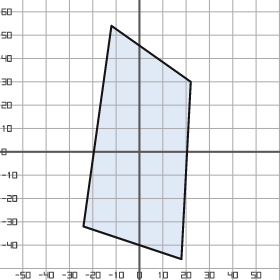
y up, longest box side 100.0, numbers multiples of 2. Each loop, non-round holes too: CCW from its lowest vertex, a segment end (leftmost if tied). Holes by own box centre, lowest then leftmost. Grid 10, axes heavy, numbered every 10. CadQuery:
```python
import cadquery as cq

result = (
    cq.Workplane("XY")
    .moveTo(18.0, -46.0)
    .lineTo(22.0, 30.0)
    .lineTo(-12.0, 54.0)
    .lineTo(-24.0, -32.0)
    .close()
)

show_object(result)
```